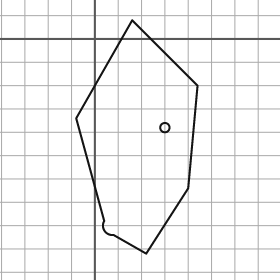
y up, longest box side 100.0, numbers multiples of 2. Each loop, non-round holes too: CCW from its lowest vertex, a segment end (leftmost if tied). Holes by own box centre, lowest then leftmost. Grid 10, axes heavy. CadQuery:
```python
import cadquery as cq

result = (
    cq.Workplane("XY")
    .moveTo(22.0, -92.0)
    .lineTo(40.0, -64.0)
    .lineTo(44.0, -20.0)
    .lineTo(16.0, 8.0)
    .lineTo(-8.0, -34.0)
    .lineTo(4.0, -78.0)
    .threePointArc((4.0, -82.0), (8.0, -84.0))
    .close()
    .moveTo(30.0, -38.0)
    .circle(2.0)
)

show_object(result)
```